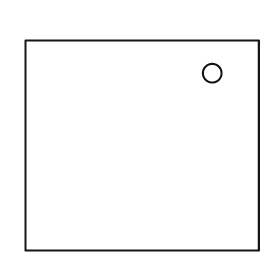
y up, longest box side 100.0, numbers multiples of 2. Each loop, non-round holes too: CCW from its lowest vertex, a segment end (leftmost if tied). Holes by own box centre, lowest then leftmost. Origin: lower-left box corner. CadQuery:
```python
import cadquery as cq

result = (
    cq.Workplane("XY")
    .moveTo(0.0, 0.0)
    .lineTo(100.0, 0.0)
    .lineTo(100.0, 90.0)
    .lineTo(0.0, 90.0)
    .close()
    .moveTo(80.0, 76.0)
    .circle(4.0)
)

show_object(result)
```